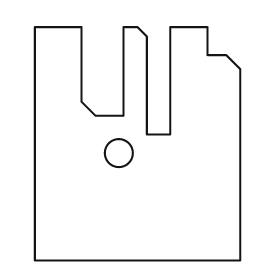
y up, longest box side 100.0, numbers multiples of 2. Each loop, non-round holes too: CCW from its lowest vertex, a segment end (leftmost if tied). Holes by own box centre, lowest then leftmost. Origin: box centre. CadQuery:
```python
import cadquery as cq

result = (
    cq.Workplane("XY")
    .moveTo(-44.0, -50.0)
    .lineTo(44.0, -50.0)
    .lineTo(44.0, 32.0)
    .lineTo(38.0, 38.0)
    .lineTo(30.0, 38.0)
    .lineTo(30.0, 50.0)
    .lineTo(14.0, 50.0)
    .lineTo(14.0, 4.0)
    .lineTo(4.0, 4.0)
    .lineTo(4.0, 46.0)
    .lineTo(0.0, 50.0)
    .lineTo(-6.0, 50.0)
    .lineTo(-6.0, 12.0)
    .lineTo(-18.0, 12.0)
    .lineTo(-24.0, 18.0)
    .lineTo(-24.0, 50.0)
    .lineTo(-44.0, 50.0)
    .close()
    .moveTo(-8.0, -4.0)
    .circle(6.0)
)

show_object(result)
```